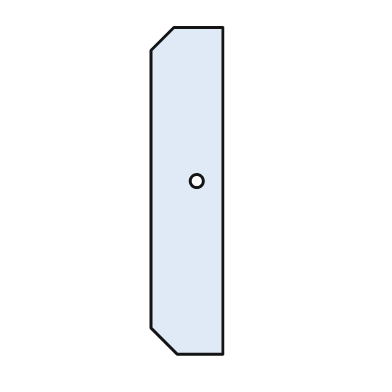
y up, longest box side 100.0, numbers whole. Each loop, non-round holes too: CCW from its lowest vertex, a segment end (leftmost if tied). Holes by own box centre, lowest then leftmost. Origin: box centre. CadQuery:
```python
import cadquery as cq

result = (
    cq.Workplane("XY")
    .moveTo(-3.0, -50.0)
    .lineTo(11.0, -50.0)
    .lineTo(11.0, 50.0)
    .lineTo(-4.0, 50.0)
    .lineTo(-11.0, 43.0)
    .lineTo(-11.0, -42.0)
    .close()
    .moveTo(3.0, 3.0)
    .circle(2.0)
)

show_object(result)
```